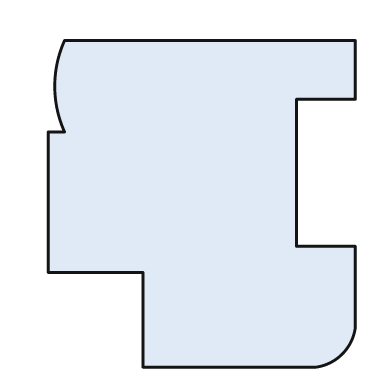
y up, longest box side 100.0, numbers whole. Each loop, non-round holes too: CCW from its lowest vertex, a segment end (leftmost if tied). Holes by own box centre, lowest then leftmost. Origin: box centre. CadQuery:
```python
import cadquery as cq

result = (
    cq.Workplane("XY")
    .moveTo(-18.0, -50.0)
    .lineTo(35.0, -50.0)
    .threePointArc((43.0, -46.0), (47.0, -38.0))
    .lineTo(47.0, -13.0)
    .lineTo(29.0, -13.0)
    .lineTo(29.0, 32.0)
    .lineTo(47.0, 32.0)
    .lineTo(47.0, 50.0)
    .lineTo(-42.0, 50.0)
    .threePointArc((-45.0, 36.0), (-42.0, 22.0))
    .lineTo(-47.0, 22.0)
    .lineTo(-47.0, -21.0)
    .lineTo(-18.0, -21.0)
    .close()
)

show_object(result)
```